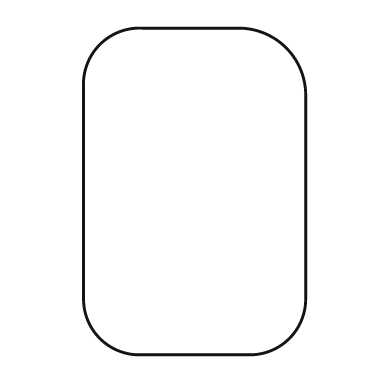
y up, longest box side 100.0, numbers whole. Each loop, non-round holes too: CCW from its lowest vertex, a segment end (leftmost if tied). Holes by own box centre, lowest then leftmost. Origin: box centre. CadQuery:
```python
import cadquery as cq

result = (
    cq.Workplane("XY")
    .moveTo(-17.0, -50.0)
    .lineTo(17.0, -50.0)
    .threePointArc((29.0, -45.0), (34.0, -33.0))
    .lineTo(34.0, 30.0)
    .threePointArc((28.0, 44.0), (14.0, 50.0))
    .lineTo(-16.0, 50.0)
    .threePointArc((-29.0, 45.0), (-34.0, 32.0))
    .lineTo(-34.0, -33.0)
    .threePointArc((-29.0, -45.0), (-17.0, -50.0))
    .close()
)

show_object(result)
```